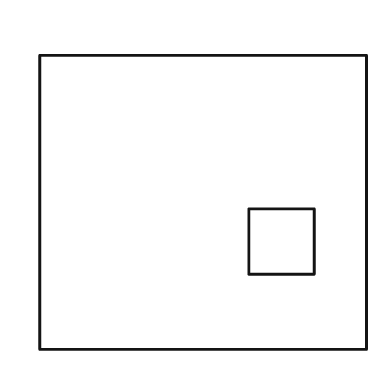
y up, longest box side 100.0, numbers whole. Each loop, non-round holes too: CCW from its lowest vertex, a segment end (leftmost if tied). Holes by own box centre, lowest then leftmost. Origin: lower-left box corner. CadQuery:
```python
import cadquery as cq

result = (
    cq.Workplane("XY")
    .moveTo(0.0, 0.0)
    .lineTo(100.0, 0.0)
    .lineTo(100.0, 90.0)
    .lineTo(0.0, 90.0)
    .close()
    .moveTo(64.0, 23.0)
    .lineTo(84.0, 23.0)
    .lineTo(84.0, 43.0)
    .lineTo(64.0, 43.0)
    .close()
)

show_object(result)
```